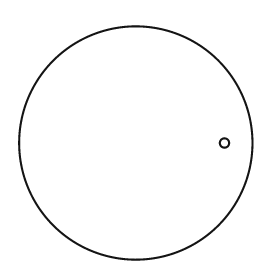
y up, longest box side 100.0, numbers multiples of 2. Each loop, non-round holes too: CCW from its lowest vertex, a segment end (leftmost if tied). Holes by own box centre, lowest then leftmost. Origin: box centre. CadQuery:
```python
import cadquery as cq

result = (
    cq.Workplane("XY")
    .moveTo(0.0, 0.0)
    .circle(50.0)
    .moveTo(38.0, 0.0)
    .circle(2.0)
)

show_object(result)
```